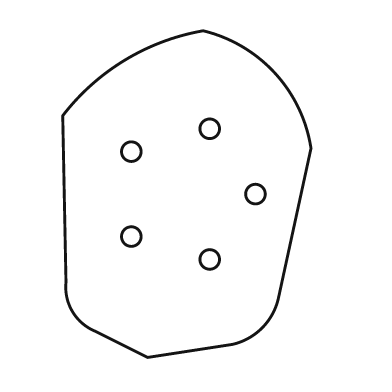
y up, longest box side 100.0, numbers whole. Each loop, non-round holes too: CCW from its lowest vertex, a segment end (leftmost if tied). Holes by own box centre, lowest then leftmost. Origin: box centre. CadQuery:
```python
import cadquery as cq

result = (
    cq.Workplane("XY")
    .moveTo(-12.0, -50.0)
    .lineTo(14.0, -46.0)
    .threePointArc((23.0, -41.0), (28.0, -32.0))
    .lineTo(38.0, 14.0)
    .threePointArc((27.0, 37.0), (5.0, 50.0))
    .threePointArc((-19.0, 41.0), (-38.0, 24.0))
    .lineTo(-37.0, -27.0)
    .threePointArc((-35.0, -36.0), (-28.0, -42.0))
    .close()
    .moveTo(7.0, -20.0)
    .circle(3.0)
    .moveTo(-17.0, -13.0)
    .circle(3.0)
    .moveTo(21.0, 0.0)
    .circle(3.0)
    .moveTo(-17.0, 13.0)
    .circle(3.0)
    .moveTo(7.0, 20.0)
    .circle(3.0)
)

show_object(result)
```